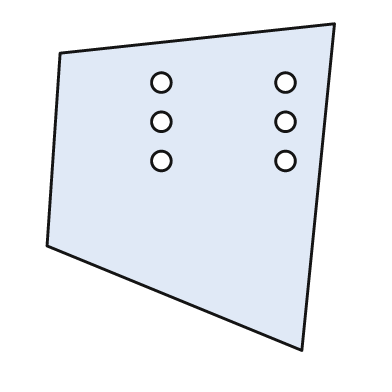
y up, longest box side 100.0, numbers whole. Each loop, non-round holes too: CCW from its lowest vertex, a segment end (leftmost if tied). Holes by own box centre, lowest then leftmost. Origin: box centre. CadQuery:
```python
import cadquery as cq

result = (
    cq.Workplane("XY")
    .moveTo(34.0, -50.0)
    .lineTo(44.0, 50.0)
    .lineTo(-40.0, 41.0)
    .lineTo(-44.0, -18.0)
    .close()
    .moveTo(-9.0, 8.0)
    .circle(3.0)
    .moveTo(29.0, 8.0)
    .circle(3.0)
    .moveTo(-9.0, 20.0)
    .circle(3.0)
    .moveTo(29.0, 20.0)
    .circle(3.0)
    .moveTo(-9.0, 32.0)
    .circle(3.0)
    .moveTo(29.0, 32.0)
    .circle(3.0)
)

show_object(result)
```